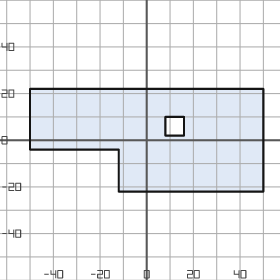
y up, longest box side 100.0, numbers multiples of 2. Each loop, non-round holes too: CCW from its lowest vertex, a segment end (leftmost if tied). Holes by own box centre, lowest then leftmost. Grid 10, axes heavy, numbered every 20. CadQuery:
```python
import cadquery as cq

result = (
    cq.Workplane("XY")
    .moveTo(-12.0, -22.0)
    .lineTo(50.0, -22.0)
    .lineTo(50.0, 22.0)
    .lineTo(-50.0, 22.0)
    .lineTo(-50.0, -4.0)
    .lineTo(-12.0, -4.0)
    .close()
    .moveTo(8.0, 2.0)
    .lineTo(16.0, 2.0)
    .lineTo(16.0, 10.0)
    .lineTo(8.0, 10.0)
    .close()
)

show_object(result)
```